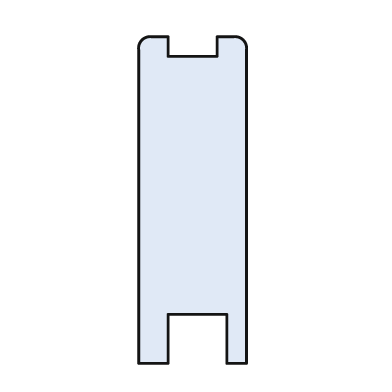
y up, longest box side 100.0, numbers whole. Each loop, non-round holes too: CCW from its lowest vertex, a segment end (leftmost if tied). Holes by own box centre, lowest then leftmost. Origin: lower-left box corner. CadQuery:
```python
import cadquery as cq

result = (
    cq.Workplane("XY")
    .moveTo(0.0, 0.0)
    .lineTo(9.0, 0.0)
    .lineTo(9.0, 15.0)
    .lineTo(27.0, 15.0)
    .lineTo(27.0, 0.0)
    .lineTo(33.0, 0.0)
    .lineTo(33.0, 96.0)
    .threePointArc((32.0, 99.0), (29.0, 100.0))
    .lineTo(24.0, 100.0)
    .lineTo(24.0, 94.0)
    .lineTo(9.0, 94.0)
    .lineTo(9.0, 100.0)
    .lineTo(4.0, 100.0)
    .threePointArc((1.0, 99.0), (0.0, 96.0))
    .close()
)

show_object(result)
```